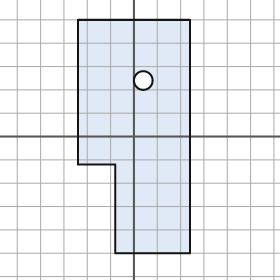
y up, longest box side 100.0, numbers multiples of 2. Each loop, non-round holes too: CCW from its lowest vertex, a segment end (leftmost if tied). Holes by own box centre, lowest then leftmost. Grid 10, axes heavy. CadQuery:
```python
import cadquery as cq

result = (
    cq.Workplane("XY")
    .moveTo(-8.0, -50.0)
    .lineTo(24.0, -50.0)
    .lineTo(24.0, 50.0)
    .lineTo(-24.0, 50.0)
    .lineTo(-24.0, -12.0)
    .lineTo(-8.0, -12.0)
    .close()
    .moveTo(4.0, 24.0)
    .circle(4.0)
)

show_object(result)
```